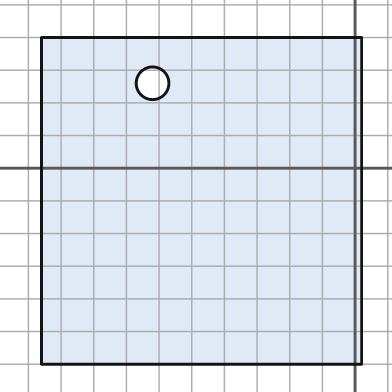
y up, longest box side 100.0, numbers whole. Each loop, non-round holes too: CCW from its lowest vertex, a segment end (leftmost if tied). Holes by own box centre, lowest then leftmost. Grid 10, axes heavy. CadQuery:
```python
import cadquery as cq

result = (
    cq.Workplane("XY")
    .moveTo(-96.0, -60.0)
    .lineTo(2.0, -60.0)
    .lineTo(2.0, 40.0)
    .lineTo(-96.0, 40.0)
    .close()
    .moveTo(-62.0, 26.0)
    .circle(5.0)
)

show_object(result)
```